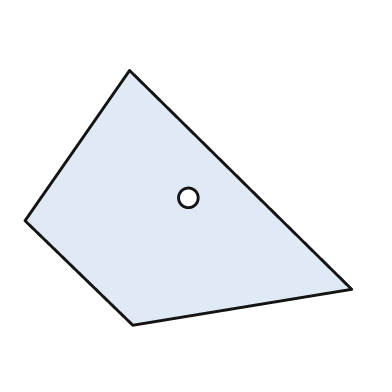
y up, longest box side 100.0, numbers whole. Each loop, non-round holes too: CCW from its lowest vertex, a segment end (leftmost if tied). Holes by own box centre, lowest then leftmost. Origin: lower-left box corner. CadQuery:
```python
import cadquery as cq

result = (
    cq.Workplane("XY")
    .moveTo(33.0, 0.0)
    .lineTo(100.0, 11.0)
    .lineTo(32.0, 78.0)
    .lineTo(0.0, 32.0)
    .close()
    .moveTo(50.0, 39.0)
    .circle(3.0)
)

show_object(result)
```